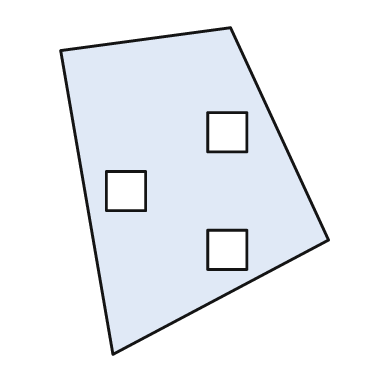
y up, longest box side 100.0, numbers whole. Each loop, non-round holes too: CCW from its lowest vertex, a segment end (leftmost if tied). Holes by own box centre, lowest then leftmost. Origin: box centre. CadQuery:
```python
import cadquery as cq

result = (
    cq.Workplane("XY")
    .moveTo(-25.0, -50.0)
    .lineTo(41.0, -15.0)
    .lineTo(11.0, 50.0)
    .lineTo(-41.0, 43.0)
    .close()
    .moveTo(4.0, -24.0)
    .lineTo(16.0, -24.0)
    .lineTo(16.0, -12.0)
    .lineTo(4.0, -12.0)
    .close()
    .moveTo(-27.0, -6.0)
    .lineTo(-15.0, -6.0)
    .lineTo(-15.0, 6.0)
    .lineTo(-27.0, 6.0)
    .close()
    .moveTo(4.0, 12.0)
    .lineTo(16.0, 12.0)
    .lineTo(16.0, 24.0)
    .lineTo(4.0, 24.0)
    .close()
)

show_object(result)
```